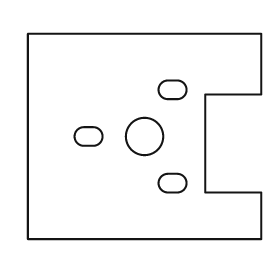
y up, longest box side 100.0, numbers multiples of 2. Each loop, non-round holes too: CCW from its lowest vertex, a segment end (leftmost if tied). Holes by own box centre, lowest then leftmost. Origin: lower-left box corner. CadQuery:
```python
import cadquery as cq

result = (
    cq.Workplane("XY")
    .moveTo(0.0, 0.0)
    .lineTo(100.0, 0.0)
    .lineTo(100.0, 20.0)
    .lineTo(76.0, 20.0)
    .lineTo(76.0, 62.0)
    .lineTo(100.0, 62.0)
    .lineTo(100.0, 88.0)
    .lineTo(0.0, 88.0)
    .close()
    .moveTo(60.0, 20.0)
    .lineTo(64.0, 20.0)
    .threePointArc((68.0, 24.0), (64.0, 28.0))
    .lineTo(60.0, 28.0)
    .threePointArc((56.0, 24.0), (60.0, 20.0))
    .close()
    .moveTo(24.0, 40.0)
    .lineTo(28.0, 40.0)
    .threePointArc((32.0, 44.0), (28.0, 48.0))
    .lineTo(24.0, 48.0)
    .threePointArc((20.0, 44.0), (24.0, 40.0))
    .close()
    .moveTo(50.0, 44.0)
    .circle(8.0)
    .moveTo(60.0, 60.0)
    .lineTo(64.0, 60.0)
    .threePointArc((68.0, 64.0), (64.0, 68.0))
    .lineTo(60.0, 68.0)
    .threePointArc((56.0, 64.0), (60.0, 60.0))
    .close()
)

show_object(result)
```